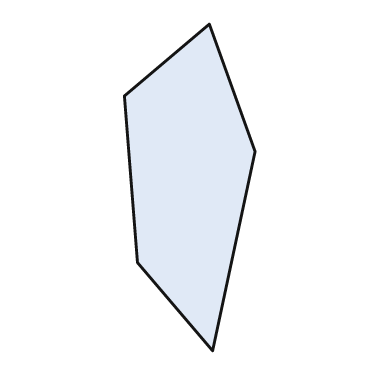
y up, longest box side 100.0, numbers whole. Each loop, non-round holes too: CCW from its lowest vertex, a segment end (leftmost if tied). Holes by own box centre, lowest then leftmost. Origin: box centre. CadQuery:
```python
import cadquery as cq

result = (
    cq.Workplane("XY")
    .moveTo(7.0, -50.0)
    .lineTo(20.0, 11.0)
    .lineTo(6.0, 50.0)
    .lineTo(-20.0, 28.0)
    .lineTo(-16.0, -23.0)
    .close()
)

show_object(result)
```